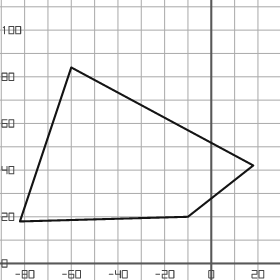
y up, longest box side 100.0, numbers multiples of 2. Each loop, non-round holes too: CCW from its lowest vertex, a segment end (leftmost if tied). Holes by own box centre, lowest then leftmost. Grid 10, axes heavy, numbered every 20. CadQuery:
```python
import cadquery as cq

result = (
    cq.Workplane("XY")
    .moveTo(-82.0, 18.0)
    .lineTo(-10.0, 20.0)
    .lineTo(18.0, 42.0)
    .lineTo(-60.0, 84.0)
    .close()
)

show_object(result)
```